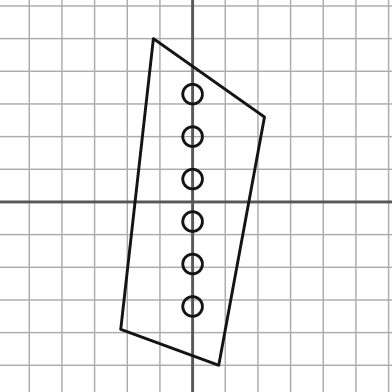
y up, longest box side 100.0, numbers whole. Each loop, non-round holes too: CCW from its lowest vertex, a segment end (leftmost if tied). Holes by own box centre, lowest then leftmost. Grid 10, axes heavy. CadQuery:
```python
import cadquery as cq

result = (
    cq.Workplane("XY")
    .moveTo(8.0, -50.0)
    .lineTo(22.0, 26.0)
    .lineTo(-12.0, 50.0)
    .lineTo(-22.0, -39.0)
    .close()
    .moveTo(0.0, -32.0)
    .circle(3.0)
    .moveTo(0.0, -19.0)
    .circle(3.0)
    .moveTo(0.0, -6.0)
    .circle(3.0)
    .moveTo(0.0, 7.0)
    .circle(3.0)
    .moveTo(0.0, 20.0)
    .circle(3.0)
    .moveTo(0.0, 33.0)
    .circle(3.0)
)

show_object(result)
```